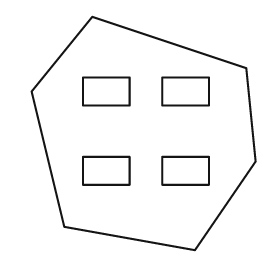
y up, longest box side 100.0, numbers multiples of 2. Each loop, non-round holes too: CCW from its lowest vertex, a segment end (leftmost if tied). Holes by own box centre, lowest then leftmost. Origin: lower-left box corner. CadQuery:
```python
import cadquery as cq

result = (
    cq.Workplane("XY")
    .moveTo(70.0, 0.0)
    .lineTo(96.0, 38.0)
    .lineTo(92.0, 78.0)
    .lineTo(26.0, 100.0)
    .lineTo(0.0, 68.0)
    .lineTo(14.0, 10.0)
    .close()
    .moveTo(22.0, 28.0)
    .lineTo(42.0, 28.0)
    .lineTo(42.0, 40.0)
    .lineTo(22.0, 40.0)
    .close()
    .moveTo(56.0, 28.0)
    .lineTo(76.0, 28.0)
    .lineTo(76.0, 40.0)
    .lineTo(56.0, 40.0)
    .close()
    .moveTo(22.0, 62.0)
    .lineTo(42.0, 62.0)
    .lineTo(42.0, 74.0)
    .lineTo(22.0, 74.0)
    .close()
    .moveTo(56.0, 62.0)
    .lineTo(76.0, 62.0)
    .lineTo(76.0, 74.0)
    .lineTo(56.0, 74.0)
    .close()
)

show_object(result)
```